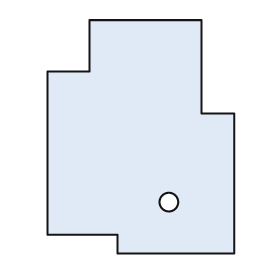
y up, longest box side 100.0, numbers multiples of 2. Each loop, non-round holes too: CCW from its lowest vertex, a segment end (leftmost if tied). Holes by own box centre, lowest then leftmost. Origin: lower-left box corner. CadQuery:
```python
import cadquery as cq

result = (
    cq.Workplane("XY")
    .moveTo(30.0, 0.0)
    .lineTo(80.0, 0.0)
    .lineTo(80.0, 60.0)
    .lineTo(66.0, 60.0)
    .lineTo(66.0, 100.0)
    .lineTo(18.0, 100.0)
    .lineTo(18.0, 78.0)
    .lineTo(0.0, 78.0)
    .lineTo(0.0, 8.0)
    .lineTo(30.0, 8.0)
    .close()
    .moveTo(52.0, 22.0)
    .circle(4.0)
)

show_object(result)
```